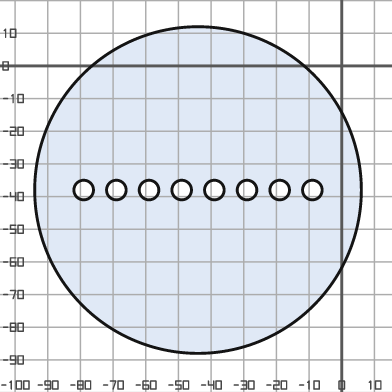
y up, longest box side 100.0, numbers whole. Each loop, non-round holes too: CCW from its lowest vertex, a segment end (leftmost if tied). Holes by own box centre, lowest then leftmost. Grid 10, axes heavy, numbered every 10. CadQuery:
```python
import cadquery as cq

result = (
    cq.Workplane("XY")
    .moveTo(-44.0, -38.0)
    .circle(50.0)
    .moveTo(-79.0, -38.0)
    .circle(3.0)
    .moveTo(-69.0, -38.0)
    .circle(3.0)
    .moveTo(-59.0, -38.0)
    .circle(3.0)
    .moveTo(-49.0, -38.0)
    .circle(3.0)
    .moveTo(-39.0, -38.0)
    .circle(3.0)
    .moveTo(-29.0, -38.0)
    .circle(3.0)
    .moveTo(-19.0, -38.0)
    .circle(3.0)
    .moveTo(-9.0, -38.0)
    .circle(3.0)
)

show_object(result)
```